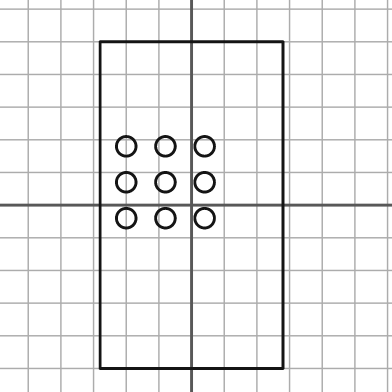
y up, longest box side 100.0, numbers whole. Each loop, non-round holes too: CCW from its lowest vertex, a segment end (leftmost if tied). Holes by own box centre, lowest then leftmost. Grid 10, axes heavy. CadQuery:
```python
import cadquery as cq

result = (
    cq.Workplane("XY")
    .moveTo(-28.0, -50.0)
    .lineTo(28.0, -50.0)
    .lineTo(28.0, 50.0)
    .lineTo(-28.0, 50.0)
    .close()
    .moveTo(-20.0, -4.0)
    .circle(3.0)
    .moveTo(-8.0, -4.0)
    .circle(3.0)
    .moveTo(4.0, -4.0)
    .circle(3.0)
    .moveTo(-20.0, 7.0)
    .circle(3.0)
    .moveTo(-8.0, 7.0)
    .circle(3.0)
    .moveTo(4.0, 7.0)
    .circle(3.0)
    .moveTo(-20.0, 18.0)
    .circle(3.0)
    .moveTo(-8.0, 18.0)
    .circle(3.0)
    .moveTo(4.0, 18.0)
    .circle(3.0)
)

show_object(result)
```